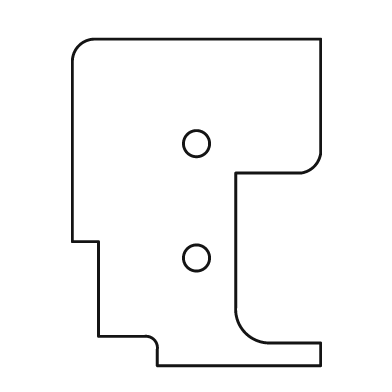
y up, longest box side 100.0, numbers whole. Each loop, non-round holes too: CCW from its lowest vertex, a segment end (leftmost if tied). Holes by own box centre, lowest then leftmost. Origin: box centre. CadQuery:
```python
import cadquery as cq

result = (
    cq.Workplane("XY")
    .moveTo(-12.0, -50.0)
    .lineTo(38.0, -50.0)
    .lineTo(38.0, -43.0)
    .lineTo(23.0, -43.0)
    .threePointArc((15.0, -40.0), (12.0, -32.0))
    .lineTo(12.0, 9.0)
    .lineTo(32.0, 9.0)
    .threePointArc((36.0, 11.0), (38.0, 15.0))
    .lineTo(38.0, 50.0)
    .lineTo(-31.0, 50.0)
    .threePointArc((-36.0, 48.0), (-38.0, 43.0))
    .lineTo(-38.0, -12.0)
    .lineTo(-30.0, -12.0)
    .lineTo(-30.0, -41.0)
    .lineTo(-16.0, -41.0)
    .threePointArc((-13.0, -42.0), (-12.0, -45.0))
    .close()
    .moveTo(0.0, -17.0)
    .circle(4.0)
    .moveTo(0.0, 18.0)
    .circle(4.0)
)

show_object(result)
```